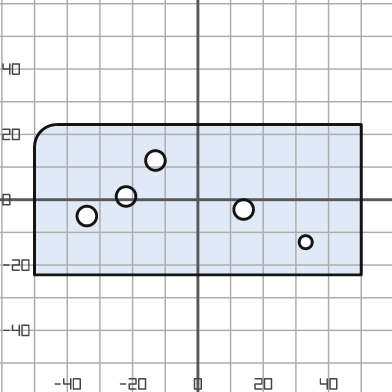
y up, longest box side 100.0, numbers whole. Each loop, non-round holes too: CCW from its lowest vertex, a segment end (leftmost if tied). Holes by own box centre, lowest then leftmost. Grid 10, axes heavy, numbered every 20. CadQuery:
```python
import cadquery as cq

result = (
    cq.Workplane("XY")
    .moveTo(-50.0, -23.0)
    .lineTo(50.0, -23.0)
    .lineTo(50.0, 23.0)
    .lineTo(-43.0, 23.0)
    .threePointArc((-48.0, 21.0), (-50.0, 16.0))
    .close()
    .moveTo(33.0, -13.0)
    .circle(2.0)
    .moveTo(-34.0, -5.0)
    .circle(3.0)
    .moveTo(14.0, -3.0)
    .circle(3.0)
    .moveTo(-22.0, 1.0)
    .circle(3.0)
    .moveTo(-13.0, 12.0)
    .circle(3.0)
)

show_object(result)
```